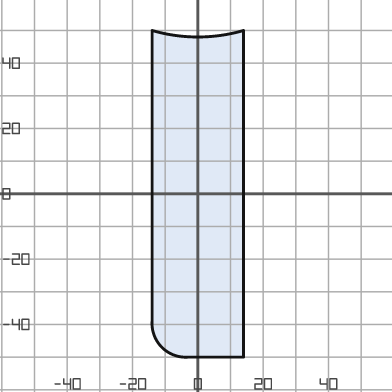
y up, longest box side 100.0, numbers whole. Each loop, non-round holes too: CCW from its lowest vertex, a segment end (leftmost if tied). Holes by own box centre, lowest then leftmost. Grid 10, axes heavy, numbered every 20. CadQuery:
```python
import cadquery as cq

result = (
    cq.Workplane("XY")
    .moveTo(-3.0, -50.0)
    .lineTo(14.0, -50.0)
    .lineTo(14.0, 50.0)
    .threePointArc((0.0, 48.0), (-14.0, 50.0))
    .lineTo(-14.0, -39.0)
    .threePointArc((-11.0, -47.0), (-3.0, -50.0))
    .close()
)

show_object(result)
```